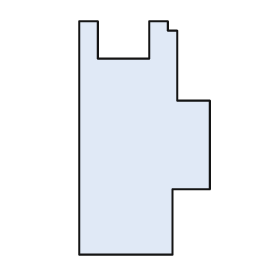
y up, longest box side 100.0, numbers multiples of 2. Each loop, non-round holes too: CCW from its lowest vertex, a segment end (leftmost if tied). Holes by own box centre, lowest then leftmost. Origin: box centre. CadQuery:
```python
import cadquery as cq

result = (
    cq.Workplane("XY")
    .moveTo(-28.0, -50.0)
    .lineTo(12.0, -50.0)
    .lineTo(12.0, -22.0)
    .lineTo(28.0, -22.0)
    .lineTo(28.0, 16.0)
    .lineTo(14.0, 16.0)
    .lineTo(14.0, 46.0)
    .lineTo(10.0, 46.0)
    .lineTo(10.0, 50.0)
    .lineTo(2.0, 50.0)
    .lineTo(2.0, 34.0)
    .lineTo(-20.0, 34.0)
    .lineTo(-20.0, 50.0)
    .lineTo(-28.0, 50.0)
    .close()
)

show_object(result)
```